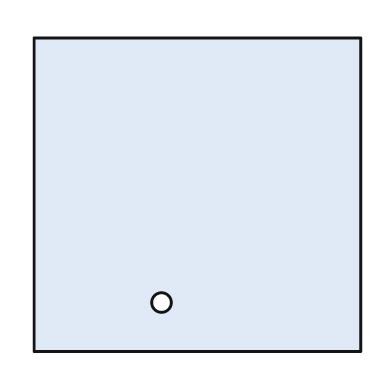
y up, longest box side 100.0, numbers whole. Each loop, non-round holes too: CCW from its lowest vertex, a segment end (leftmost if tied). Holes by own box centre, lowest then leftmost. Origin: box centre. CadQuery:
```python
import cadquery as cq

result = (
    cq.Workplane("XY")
    .moveTo(-50.0, -48.0)
    .lineTo(50.0, -48.0)
    .lineTo(50.0, 48.0)
    .lineTo(-50.0, 48.0)
    .close()
    .moveTo(-11.0, -33.0)
    .circle(3.0)
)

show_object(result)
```